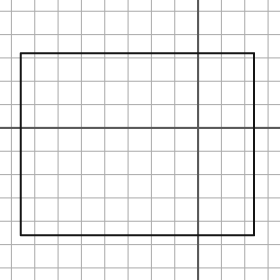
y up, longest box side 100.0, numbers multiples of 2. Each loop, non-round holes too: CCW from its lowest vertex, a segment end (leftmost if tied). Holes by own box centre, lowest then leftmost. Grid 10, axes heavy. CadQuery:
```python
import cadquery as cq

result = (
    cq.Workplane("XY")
    .moveTo(-76.0, -46.0)
    .lineTo(24.0, -46.0)
    .lineTo(24.0, 32.0)
    .lineTo(-76.0, 32.0)
    .close()
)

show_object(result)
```